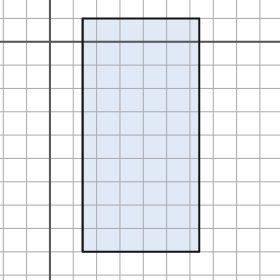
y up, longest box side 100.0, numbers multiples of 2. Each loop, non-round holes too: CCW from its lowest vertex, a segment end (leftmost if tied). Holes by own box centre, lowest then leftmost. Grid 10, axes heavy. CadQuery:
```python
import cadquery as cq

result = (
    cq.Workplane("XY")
    .moveTo(14.0, -90.0)
    .lineTo(64.0, -90.0)
    .lineTo(64.0, 10.0)
    .lineTo(14.0, 10.0)
    .close()
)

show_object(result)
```